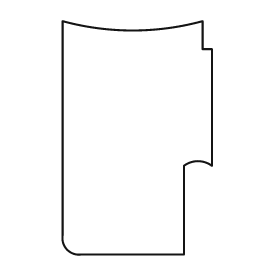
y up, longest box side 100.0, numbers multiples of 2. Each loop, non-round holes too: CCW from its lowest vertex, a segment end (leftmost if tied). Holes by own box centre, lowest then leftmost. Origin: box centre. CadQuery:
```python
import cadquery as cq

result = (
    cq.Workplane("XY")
    .moveTo(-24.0, -50.0)
    .lineTo(20.0, -50.0)
    .lineTo(20.0, -12.0)
    .threePointArc((26.0, -10.0), (32.0, -12.0))
    .lineTo(32.0, 38.0)
    .lineTo(28.0, 38.0)
    .lineTo(28.0, 50.0)
    .threePointArc((-2.0, 46.0), (-32.0, 50.0))
    .lineTo(-32.0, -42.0)
    .threePointArc((-30.0, -48.0), (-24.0, -50.0))
    .close()
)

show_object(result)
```